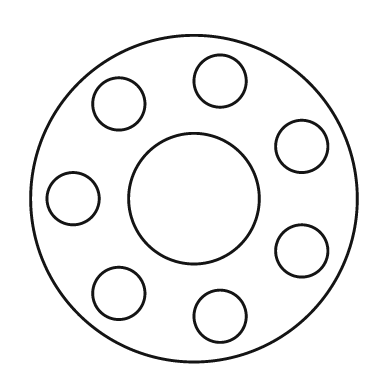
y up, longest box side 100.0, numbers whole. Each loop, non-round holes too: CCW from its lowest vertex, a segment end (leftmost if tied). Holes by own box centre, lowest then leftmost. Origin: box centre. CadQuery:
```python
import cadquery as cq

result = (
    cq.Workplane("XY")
    .moveTo(0.0, 0.0)
    .circle(50.0)
    .moveTo(8.0, -36.0)
    .circle(8.0)
    .moveTo(-23.0, -29.0)
    .circle(8.0)
    .moveTo(33.0, -16.0)
    .circle(8.0)
    .moveTo(-37.0, 0.0)
    .circle(8.0)
    .moveTo(0.0, 0.0)
    .circle(20.0)
    .moveTo(33.0, 16.0)
    .circle(8.0)
    .moveTo(-23.0, 29.0)
    .circle(8.0)
    .moveTo(8.0, 36.0)
    .circle(8.0)
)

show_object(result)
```